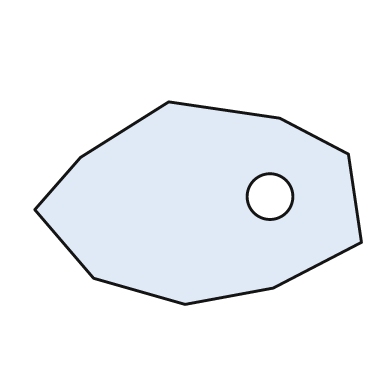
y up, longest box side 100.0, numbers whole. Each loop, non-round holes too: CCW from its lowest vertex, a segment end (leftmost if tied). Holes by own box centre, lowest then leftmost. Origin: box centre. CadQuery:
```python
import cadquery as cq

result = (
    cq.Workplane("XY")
    .moveTo(-4.0, -31.0)
    .lineTo(23.0, -26.0)
    .lineTo(50.0, -12.0)
    .lineTo(46.0, 15.0)
    .lineTo(25.0, 26.0)
    .lineTo(-9.0, 31.0)
    .lineTo(-36.0, 14.0)
    .lineTo(-50.0, -2.0)
    .lineTo(-32.0, -23.0)
    .close()
    .moveTo(22.0, 2.0)
    .circle(7.0)
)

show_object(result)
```